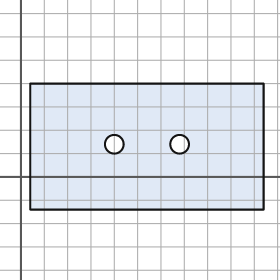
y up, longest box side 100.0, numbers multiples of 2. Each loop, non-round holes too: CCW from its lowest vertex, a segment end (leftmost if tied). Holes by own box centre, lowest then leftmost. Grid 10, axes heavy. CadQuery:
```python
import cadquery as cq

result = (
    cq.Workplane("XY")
    .moveTo(4.0, -14.0)
    .lineTo(104.0, -14.0)
    .lineTo(104.0, 40.0)
    .lineTo(4.0, 40.0)
    .close()
    .moveTo(40.0, 14.0)
    .circle(4.0)
    .moveTo(68.0, 14.0)
    .circle(4.0)
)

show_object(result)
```